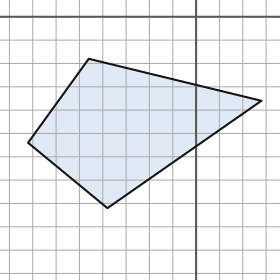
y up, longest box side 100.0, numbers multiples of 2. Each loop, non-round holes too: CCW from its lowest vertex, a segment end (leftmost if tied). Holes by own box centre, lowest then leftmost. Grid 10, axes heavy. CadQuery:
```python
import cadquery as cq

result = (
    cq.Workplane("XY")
    .moveTo(-38.0, -82.0)
    .lineTo(28.0, -36.0)
    .lineTo(-46.0, -18.0)
    .lineTo(-72.0, -54.0)
    .close()
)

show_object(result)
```